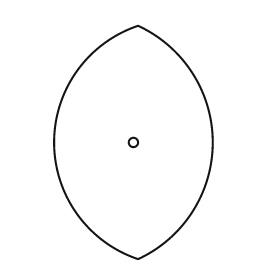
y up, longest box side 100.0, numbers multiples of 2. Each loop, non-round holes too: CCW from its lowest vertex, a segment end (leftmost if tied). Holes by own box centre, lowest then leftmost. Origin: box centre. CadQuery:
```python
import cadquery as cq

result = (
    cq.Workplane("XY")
    .moveTo(2.0, -50.0)
    .threePointArc((34.0, 0.0), (2.0, 50.0))
    .threePointArc((-34.0, 0.0), (2.0, -50.0))
    .close()
    .moveTo(0.0, 0.0)
    .circle(2.0)
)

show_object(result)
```